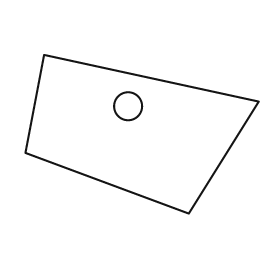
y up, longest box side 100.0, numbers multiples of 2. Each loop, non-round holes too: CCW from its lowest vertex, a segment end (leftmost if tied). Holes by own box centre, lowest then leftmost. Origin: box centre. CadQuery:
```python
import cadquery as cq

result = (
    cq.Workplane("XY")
    .moveTo(20.0, -34.0)
    .lineTo(50.0, 14.0)
    .lineTo(-42.0, 34.0)
    .lineTo(-50.0, -8.0)
    .close()
    .moveTo(-6.0, 12.0)
    .circle(6.0)
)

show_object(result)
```